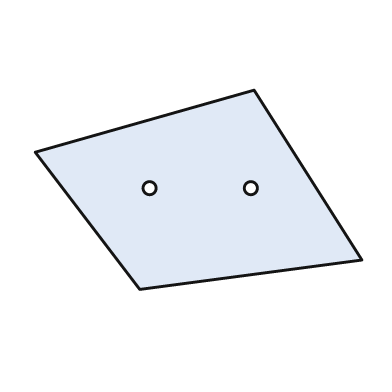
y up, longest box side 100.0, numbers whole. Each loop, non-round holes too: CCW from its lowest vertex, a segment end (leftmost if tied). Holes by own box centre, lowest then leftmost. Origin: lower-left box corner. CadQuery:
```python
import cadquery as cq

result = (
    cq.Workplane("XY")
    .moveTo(32.0, 0.0)
    .lineTo(100.0, 9.0)
    .lineTo(67.0, 61.0)
    .lineTo(0.0, 42.0)
    .close()
    .moveTo(35.0, 31.0)
    .circle(2.0)
    .moveTo(66.0, 31.0)
    .circle(2.0)
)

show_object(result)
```